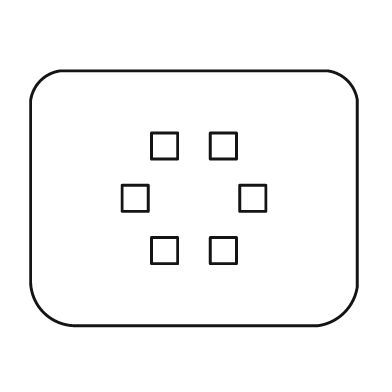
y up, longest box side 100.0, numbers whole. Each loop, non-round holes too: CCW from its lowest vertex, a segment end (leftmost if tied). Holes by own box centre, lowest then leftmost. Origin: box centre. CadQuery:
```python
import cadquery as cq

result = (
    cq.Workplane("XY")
    .moveTo(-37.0, -39.0)
    .lineTo(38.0, -39.0)
    .threePointArc((46.0, -35.0), (50.0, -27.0))
    .lineTo(50.0, 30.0)
    .threePointArc((47.0, 36.0), (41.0, 39.0))
    .lineTo(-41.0, 39.0)
    .threePointArc((-47.0, 36.0), (-50.0, 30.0))
    .lineTo(-50.0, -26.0)
    .threePointArc((-46.0, -35.0), (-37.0, -39.0))
    .close()
    .moveTo(-13.0, -20.0)
    .lineTo(-5.0, -20.0)
    .lineTo(-5.0, -12.0)
    .lineTo(-13.0, -12.0)
    .close()
    .moveTo(5.0, -20.0)
    .lineTo(13.0, -20.0)
    .lineTo(13.0, -12.0)
    .lineTo(5.0, -12.0)
    .close()
    .moveTo(-22.0, -4.0)
    .lineTo(-14.0, -4.0)
    .lineTo(-14.0, 4.0)
    .lineTo(-22.0, 4.0)
    .close()
    .moveTo(14.0, -4.0)
    .lineTo(22.0, -4.0)
    .lineTo(22.0, 4.0)
    .lineTo(14.0, 4.0)
    .close()
    .moveTo(-13.0, 12.0)
    .lineTo(-5.0, 12.0)
    .lineTo(-5.0, 20.0)
    .lineTo(-13.0, 20.0)
    .close()
    .moveTo(5.0, 12.0)
    .lineTo(13.0, 12.0)
    .lineTo(13.0, 20.0)
    .lineTo(5.0, 20.0)
    .close()
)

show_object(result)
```